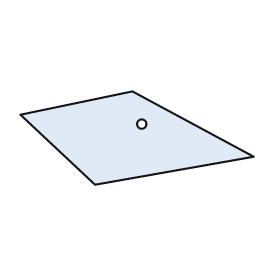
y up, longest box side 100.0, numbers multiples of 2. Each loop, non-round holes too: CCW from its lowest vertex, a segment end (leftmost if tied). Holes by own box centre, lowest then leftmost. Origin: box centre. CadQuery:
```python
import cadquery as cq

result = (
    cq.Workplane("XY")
    .moveTo(-18.0, -20.0)
    .lineTo(50.0, -8.0)
    .lineTo(-2.0, 20.0)
    .lineTo(-50.0, 10.0)
    .close()
    .moveTo(2.0, 6.0)
    .circle(2.0)
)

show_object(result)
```